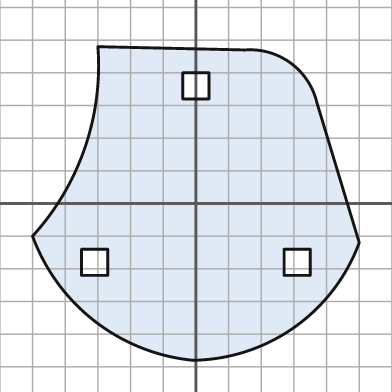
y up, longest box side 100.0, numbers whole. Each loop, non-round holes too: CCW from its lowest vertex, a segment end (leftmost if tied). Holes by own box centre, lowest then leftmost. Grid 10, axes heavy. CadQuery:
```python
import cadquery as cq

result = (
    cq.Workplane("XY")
    .moveTo(-1.0, -48.0)
    .threePointArc((30.0, -38.0), (50.0, -12.0))
    .lineTo(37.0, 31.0)
    .threePointArc((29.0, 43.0), (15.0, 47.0))
    .lineTo(-30.0, 48.0)
    .threePointArc((-34.0, 17.0), (-50.0, -10.0))
    .threePointArc((-31.0, -36.0), (-1.0, -48.0))
    .close()
    .moveTo(-35.0, -22.0)
    .lineTo(-27.0, -22.0)
    .lineTo(-27.0, -14.0)
    .lineTo(-35.0, -14.0)
    .close()
    .moveTo(27.0, -22.0)
    .lineTo(35.0, -22.0)
    .lineTo(35.0, -14.0)
    .lineTo(27.0, -14.0)
    .close()
    .moveTo(-4.0, 32.0)
    .lineTo(4.0, 32.0)
    .lineTo(4.0, 40.0)
    .lineTo(-4.0, 40.0)
    .close()
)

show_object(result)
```